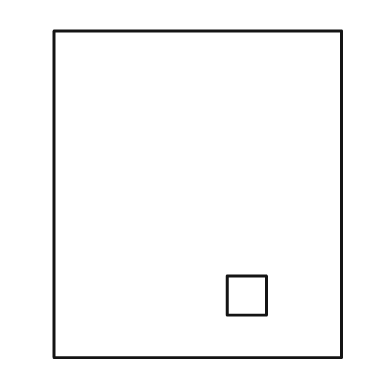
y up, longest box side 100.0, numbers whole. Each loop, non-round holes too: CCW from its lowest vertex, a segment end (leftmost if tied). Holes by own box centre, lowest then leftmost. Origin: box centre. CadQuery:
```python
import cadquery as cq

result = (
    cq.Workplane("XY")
    .moveTo(-44.0, -50.0)
    .lineTo(44.0, -50.0)
    .lineTo(44.0, 50.0)
    .lineTo(-44.0, 50.0)
    .close()
    .moveTo(9.0, -37.0)
    .lineTo(21.0, -37.0)
    .lineTo(21.0, -25.0)
    .lineTo(9.0, -25.0)
    .close()
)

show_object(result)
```